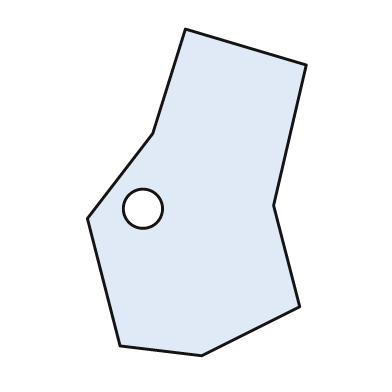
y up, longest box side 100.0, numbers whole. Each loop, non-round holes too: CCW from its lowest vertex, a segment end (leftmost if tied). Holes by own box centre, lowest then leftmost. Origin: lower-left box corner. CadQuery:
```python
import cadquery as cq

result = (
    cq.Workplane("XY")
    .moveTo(35.0, 0.0)
    .lineTo(65.0, 15.0)
    .lineTo(57.0, 46.0)
    .lineTo(67.0, 89.0)
    .lineTo(30.0, 100.0)
    .lineTo(20.0, 68.0)
    .lineTo(0.0, 42.0)
    .lineTo(10.0, 3.0)
    .close()
    .moveTo(17.0, 45.0)
    .circle(6.0)
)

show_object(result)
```